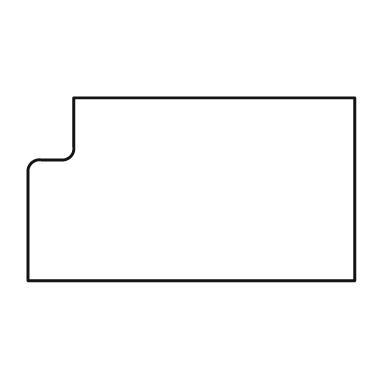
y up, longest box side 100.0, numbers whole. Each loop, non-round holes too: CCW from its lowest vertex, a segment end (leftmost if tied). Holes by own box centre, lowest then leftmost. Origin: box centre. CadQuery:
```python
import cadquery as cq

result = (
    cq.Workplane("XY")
    .moveTo(-50.0, -28.0)
    .lineTo(50.0, -28.0)
    .lineTo(50.0, 28.0)
    .lineTo(-36.0, 28.0)
    .lineTo(-36.0, 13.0)
    .threePointArc((-37.0, 10.0), (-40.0, 9.0))
    .lineTo(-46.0, 9.0)
    .threePointArc((-49.0, 8.0), (-50.0, 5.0))
    .close()
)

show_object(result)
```